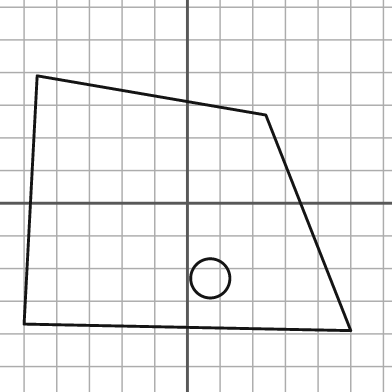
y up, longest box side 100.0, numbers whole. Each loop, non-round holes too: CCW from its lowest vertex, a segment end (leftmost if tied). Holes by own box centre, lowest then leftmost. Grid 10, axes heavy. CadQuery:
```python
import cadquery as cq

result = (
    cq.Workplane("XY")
    .moveTo(50.0, -39.0)
    .lineTo(24.0, 27.0)
    .lineTo(-46.0, 39.0)
    .lineTo(-50.0, -37.0)
    .close()
    .moveTo(7.0, -23.0)
    .circle(6.0)
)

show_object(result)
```